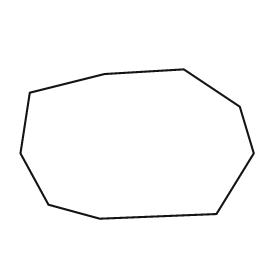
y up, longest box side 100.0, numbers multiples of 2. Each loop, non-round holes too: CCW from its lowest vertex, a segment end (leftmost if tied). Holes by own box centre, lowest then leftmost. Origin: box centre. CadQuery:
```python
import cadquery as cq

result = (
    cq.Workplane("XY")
    .moveTo(-16.0, -32.0)
    .lineTo(34.0, -30.0)
    .lineTo(50.0, -4.0)
    .lineTo(44.0, 16.0)
    .lineTo(20.0, 32.0)
    .lineTo(-14.0, 30.0)
    .lineTo(-46.0, 22.0)
    .lineTo(-50.0, -4.0)
    .lineTo(-38.0, -26.0)
    .close()
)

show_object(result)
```